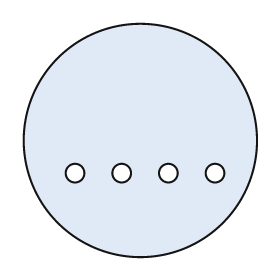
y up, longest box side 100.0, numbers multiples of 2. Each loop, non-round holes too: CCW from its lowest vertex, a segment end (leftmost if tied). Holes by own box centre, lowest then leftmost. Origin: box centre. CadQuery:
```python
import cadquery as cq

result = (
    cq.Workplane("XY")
    .moveTo(0.0, 0.0)
    .circle(50.0)
    .moveTo(-28.0, -14.0)
    .circle(4.0)
    .moveTo(-8.0, -14.0)
    .circle(4.0)
    .moveTo(12.0, -14.0)
    .circle(4.0)
    .moveTo(32.0, -14.0)
    .circle(4.0)
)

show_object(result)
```